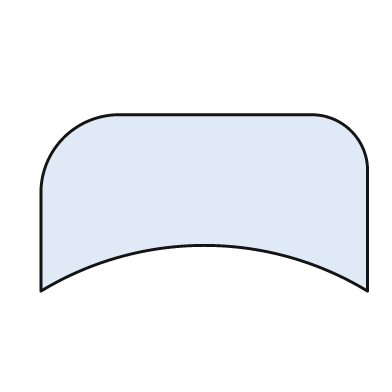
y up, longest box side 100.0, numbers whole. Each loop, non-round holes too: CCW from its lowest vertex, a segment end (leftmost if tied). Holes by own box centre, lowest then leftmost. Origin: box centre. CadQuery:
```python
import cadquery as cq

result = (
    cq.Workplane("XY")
    .moveTo(-50.0, -27.0)
    .threePointArc((0.0, -13.0), (50.0, -27.0))
    .lineTo(50.0, 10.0)
    .threePointArc((45.0, 22.0), (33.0, 27.0))
    .lineTo(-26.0, 27.0)
    .threePointArc((-43.0, 20.0), (-50.0, 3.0))
    .close()
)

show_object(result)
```